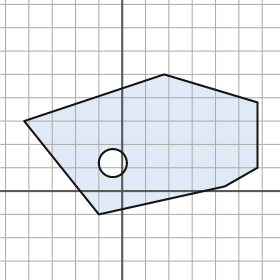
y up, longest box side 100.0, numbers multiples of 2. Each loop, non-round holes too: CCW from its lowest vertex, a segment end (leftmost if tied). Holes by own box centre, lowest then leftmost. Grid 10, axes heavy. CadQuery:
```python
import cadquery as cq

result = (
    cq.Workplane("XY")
    .moveTo(-10.0, -10.0)
    .lineTo(44.0, 2.0)
    .lineTo(58.0, 10.0)
    .lineTo(58.0, 38.0)
    .lineTo(18.0, 50.0)
    .lineTo(-42.0, 30.0)
    .close()
    .moveTo(-4.0, 12.0)
    .circle(6.0)
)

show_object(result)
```